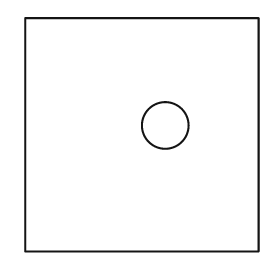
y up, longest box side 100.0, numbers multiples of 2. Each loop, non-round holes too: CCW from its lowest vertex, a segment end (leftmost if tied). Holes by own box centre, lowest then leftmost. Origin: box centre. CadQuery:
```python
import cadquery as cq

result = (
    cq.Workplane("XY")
    .moveTo(-50.0, -50.0)
    .lineTo(50.0, -50.0)
    .lineTo(50.0, 50.0)
    .lineTo(-50.0, 50.0)
    .close()
    .moveTo(10.0, 4.0)
    .circle(10.0)
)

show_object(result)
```